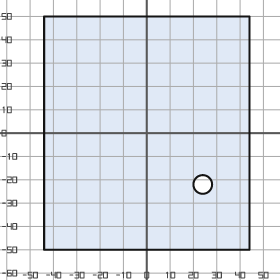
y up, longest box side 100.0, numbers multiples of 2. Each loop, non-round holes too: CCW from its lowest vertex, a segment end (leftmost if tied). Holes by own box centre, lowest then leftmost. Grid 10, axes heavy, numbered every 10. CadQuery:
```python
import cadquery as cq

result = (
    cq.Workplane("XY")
    .moveTo(-44.0, -50.0)
    .lineTo(44.0, -50.0)
    .lineTo(44.0, 50.0)
    .lineTo(-44.0, 50.0)
    .close()
    .moveTo(24.0, -22.0)
    .circle(4.0)
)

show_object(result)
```